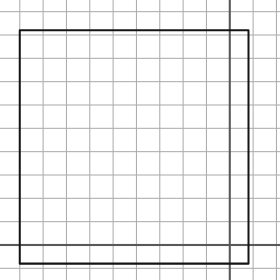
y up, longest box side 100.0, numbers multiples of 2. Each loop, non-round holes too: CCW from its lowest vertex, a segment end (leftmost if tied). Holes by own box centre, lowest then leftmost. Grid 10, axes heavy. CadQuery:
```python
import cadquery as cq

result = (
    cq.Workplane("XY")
    .moveTo(-90.0, -8.0)
    .lineTo(8.0, -8.0)
    .lineTo(8.0, 92.0)
    .lineTo(-90.0, 92.0)
    .close()
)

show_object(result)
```